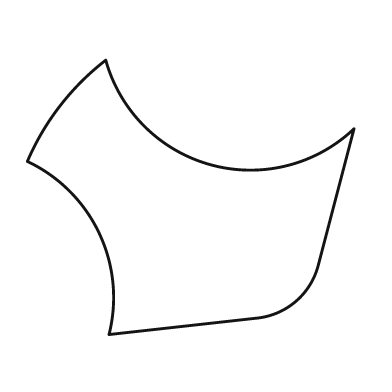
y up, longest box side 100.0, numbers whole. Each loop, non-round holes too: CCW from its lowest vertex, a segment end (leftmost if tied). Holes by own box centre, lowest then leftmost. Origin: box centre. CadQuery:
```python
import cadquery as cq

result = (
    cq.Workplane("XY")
    .moveTo(-25.0, -42.0)
    .lineTo(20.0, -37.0)
    .threePointArc((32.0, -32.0), (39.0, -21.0))
    .lineTo(50.0, 21.0)
    .threePointArc((6.0, 10.0), (-26.0, 42.0))
    .threePointArc((-40.0, 28.0), (-50.0, 11.0))
    .threePointArc((-28.0, -11.0), (-25.0, -42.0))
    .close()
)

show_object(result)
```